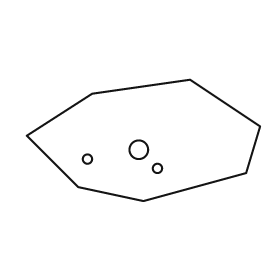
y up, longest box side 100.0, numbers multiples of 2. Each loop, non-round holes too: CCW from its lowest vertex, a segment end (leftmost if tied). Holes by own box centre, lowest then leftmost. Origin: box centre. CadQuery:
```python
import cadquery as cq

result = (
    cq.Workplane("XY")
    .moveTo(0.0, -26.0)
    .lineTo(44.0, -14.0)
    .lineTo(50.0, 6.0)
    .lineTo(20.0, 26.0)
    .lineTo(-22.0, 20.0)
    .lineTo(-50.0, 2.0)
    .lineTo(-28.0, -20.0)
    .close()
    .moveTo(6.0, -12.0)
    .circle(2.0)
    .moveTo(-24.0, -8.0)
    .circle(2.0)
    .moveTo(-2.0, -4.0)
    .circle(4.0)
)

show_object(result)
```